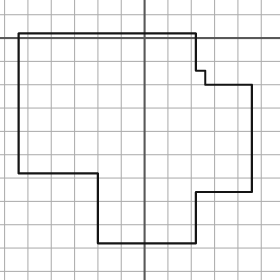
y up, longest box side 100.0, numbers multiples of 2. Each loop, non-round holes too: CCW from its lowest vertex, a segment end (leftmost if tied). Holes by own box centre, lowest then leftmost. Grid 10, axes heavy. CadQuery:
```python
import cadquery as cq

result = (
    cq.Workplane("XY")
    .moveTo(-20.0, -88.0)
    .lineTo(22.0, -88.0)
    .lineTo(22.0, -66.0)
    .lineTo(46.0, -66.0)
    .lineTo(46.0, -20.0)
    .lineTo(26.0, -20.0)
    .lineTo(26.0, -14.0)
    .lineTo(22.0, -14.0)
    .lineTo(22.0, 2.0)
    .lineTo(-54.0, 2.0)
    .lineTo(-54.0, -58.0)
    .lineTo(-20.0, -58.0)
    .close()
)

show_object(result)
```